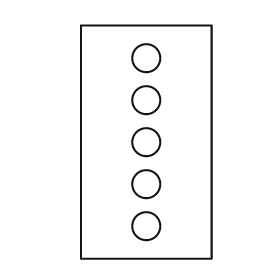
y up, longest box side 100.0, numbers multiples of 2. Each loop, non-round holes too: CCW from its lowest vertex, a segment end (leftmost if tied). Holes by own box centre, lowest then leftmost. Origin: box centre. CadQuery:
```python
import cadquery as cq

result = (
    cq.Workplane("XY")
    .moveTo(-28.0, -50.0)
    .lineTo(28.0, -50.0)
    .lineTo(28.0, 50.0)
    .lineTo(-28.0, 50.0)
    .close()
    .moveTo(0.0, -36.0)
    .circle(6.0)
    .moveTo(0.0, -18.0)
    .circle(6.0)
    .moveTo(0.0, 0.0)
    .circle(6.0)
    .moveTo(0.0, 18.0)
    .circle(6.0)
    .moveTo(0.0, 36.0)
    .circle(6.0)
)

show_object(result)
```